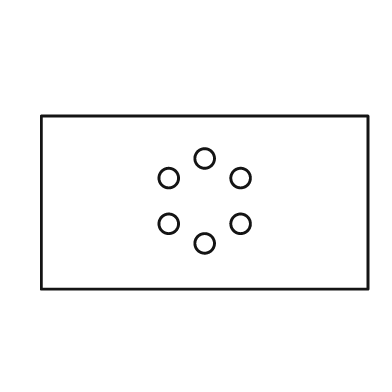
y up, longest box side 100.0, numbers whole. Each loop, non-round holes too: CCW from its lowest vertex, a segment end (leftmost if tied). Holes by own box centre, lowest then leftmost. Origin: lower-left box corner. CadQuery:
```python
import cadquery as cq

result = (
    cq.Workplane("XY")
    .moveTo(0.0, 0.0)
    .lineTo(100.0, 0.0)
    .lineTo(100.0, 53.0)
    .lineTo(0.0, 53.0)
    .close()
    .moveTo(50.0, 14.0)
    .circle(3.0)
    .moveTo(39.0, 20.0)
    .circle(3.0)
    .moveTo(61.0, 20.0)
    .circle(3.0)
    .moveTo(39.0, 34.0)
    .circle(3.0)
    .moveTo(61.0, 34.0)
    .circle(3.0)
    .moveTo(50.0, 40.0)
    .circle(3.0)
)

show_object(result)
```